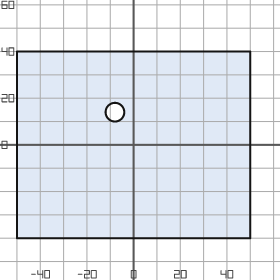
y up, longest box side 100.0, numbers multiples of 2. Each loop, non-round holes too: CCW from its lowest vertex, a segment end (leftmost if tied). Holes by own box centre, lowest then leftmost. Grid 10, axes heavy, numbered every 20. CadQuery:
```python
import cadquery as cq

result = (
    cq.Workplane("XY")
    .moveTo(-50.0, -40.0)
    .lineTo(50.0, -40.0)
    .lineTo(50.0, 40.0)
    .lineTo(-50.0, 40.0)
    .close()
    .moveTo(-8.0, 14.0)
    .circle(4.0)
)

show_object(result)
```